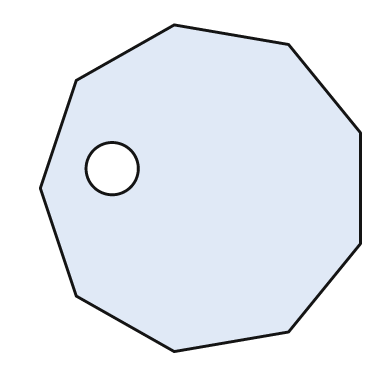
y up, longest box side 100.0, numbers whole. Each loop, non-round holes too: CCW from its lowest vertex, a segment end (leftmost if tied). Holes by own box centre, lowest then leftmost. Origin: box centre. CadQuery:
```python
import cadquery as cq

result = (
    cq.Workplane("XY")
    .moveTo(-8.0, -50.0)
    .lineTo(27.0, -44.0)
    .lineTo(49.0, -17.0)
    .lineTo(49.0, 17.0)
    .lineTo(27.0, 44.0)
    .lineTo(-8.0, 50.0)
    .lineTo(-38.0, 33.0)
    .lineTo(-49.0, 0.0)
    .lineTo(-38.0, -33.0)
    .close()
    .moveTo(-27.0, 6.0)
    .circle(8.0)
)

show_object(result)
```